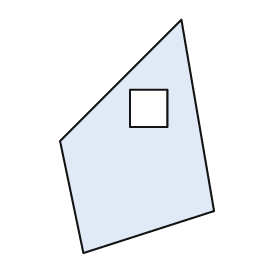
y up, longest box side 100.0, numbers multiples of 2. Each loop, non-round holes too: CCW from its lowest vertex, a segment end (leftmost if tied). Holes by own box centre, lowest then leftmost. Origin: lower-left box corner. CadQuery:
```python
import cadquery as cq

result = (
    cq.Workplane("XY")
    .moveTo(10.0, 0.0)
    .lineTo(66.0, 18.0)
    .lineTo(52.0, 100.0)
    .lineTo(0.0, 48.0)
    .close()
    .moveTo(30.0, 54.0)
    .lineTo(46.0, 54.0)
    .lineTo(46.0, 70.0)
    .lineTo(30.0, 70.0)
    .close()
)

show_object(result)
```